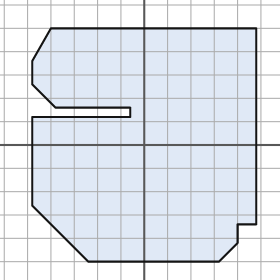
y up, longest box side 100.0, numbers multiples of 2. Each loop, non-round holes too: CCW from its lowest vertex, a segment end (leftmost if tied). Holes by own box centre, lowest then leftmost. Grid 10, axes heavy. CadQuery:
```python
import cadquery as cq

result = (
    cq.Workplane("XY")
    .moveTo(-24.0, -50.0)
    .lineTo(32.0, -50.0)
    .lineTo(40.0, -42.0)
    .lineTo(40.0, -34.0)
    .lineTo(48.0, -34.0)
    .lineTo(48.0, 50.0)
    .lineTo(-40.0, 50.0)
    .lineTo(-48.0, 36.0)
    .lineTo(-48.0, 26.0)
    .lineTo(-38.0, 16.0)
    .lineTo(-6.0, 16.0)
    .lineTo(-6.0, 12.0)
    .lineTo(-48.0, 12.0)
    .lineTo(-48.0, -26.0)
    .close()
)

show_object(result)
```